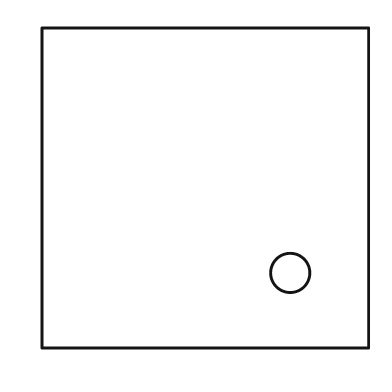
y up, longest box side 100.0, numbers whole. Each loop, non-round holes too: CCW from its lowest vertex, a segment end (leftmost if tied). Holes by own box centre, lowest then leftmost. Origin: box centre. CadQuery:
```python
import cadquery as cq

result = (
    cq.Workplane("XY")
    .moveTo(-50.0, -49.0)
    .lineTo(50.0, -49.0)
    .lineTo(50.0, 49.0)
    .lineTo(-50.0, 49.0)
    .close()
    .moveTo(26.0, -26.0)
    .circle(6.0)
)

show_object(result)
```